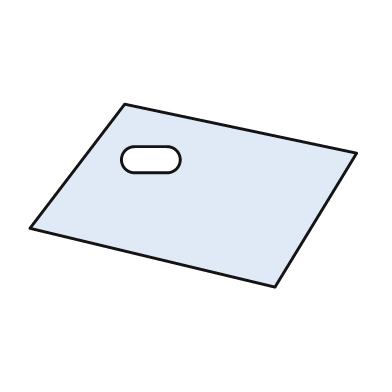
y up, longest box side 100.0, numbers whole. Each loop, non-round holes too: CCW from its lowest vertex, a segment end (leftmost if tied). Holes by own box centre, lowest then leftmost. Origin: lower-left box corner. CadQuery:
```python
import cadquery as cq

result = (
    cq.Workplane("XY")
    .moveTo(75.0, 0.0)
    .lineTo(100.0, 41.0)
    .lineTo(29.0, 56.0)
    .lineTo(0.0, 18.0)
    .close()
    .moveTo(32.0, 35.0)
    .lineTo(42.0, 35.0)
    .threePointArc((46.0, 39.0), (42.0, 43.0))
    .lineTo(32.0, 43.0)
    .threePointArc((28.0, 39.0), (32.0, 35.0))
    .close()
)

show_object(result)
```